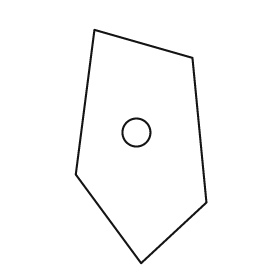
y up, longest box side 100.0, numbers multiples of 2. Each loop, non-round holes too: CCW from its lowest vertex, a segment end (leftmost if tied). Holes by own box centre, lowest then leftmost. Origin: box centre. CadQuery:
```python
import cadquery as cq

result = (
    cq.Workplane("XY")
    .moveTo(0.0, -50.0)
    .lineTo(28.0, -24.0)
    .lineTo(22.0, 38.0)
    .lineTo(-20.0, 50.0)
    .lineTo(-28.0, -12.0)
    .close()
    .moveTo(-2.0, 6.0)
    .circle(6.0)
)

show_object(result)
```